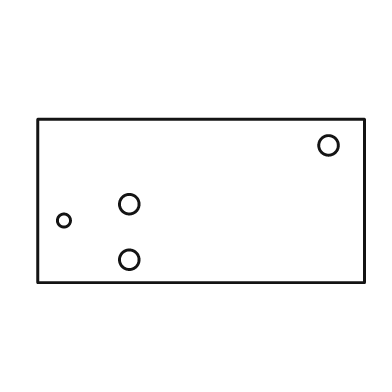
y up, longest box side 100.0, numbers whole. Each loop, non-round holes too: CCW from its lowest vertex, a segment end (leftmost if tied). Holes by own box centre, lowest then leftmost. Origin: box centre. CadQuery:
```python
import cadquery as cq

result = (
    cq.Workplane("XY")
    .moveTo(-50.0, -25.0)
    .lineTo(50.0, -25.0)
    .lineTo(50.0, 25.0)
    .lineTo(-50.0, 25.0)
    .close()
    .moveTo(-22.0, -18.0)
    .circle(3.0)
    .moveTo(-42.0, -6.0)
    .circle(2.0)
    .moveTo(-22.0, -1.0)
    .circle(3.0)
    .moveTo(39.0, 17.0)
    .circle(3.0)
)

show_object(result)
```